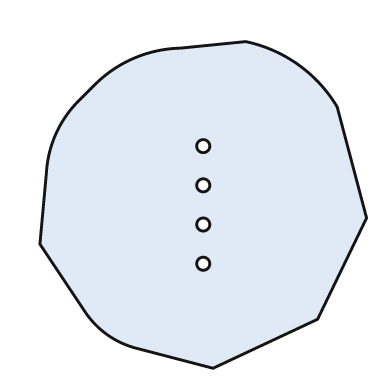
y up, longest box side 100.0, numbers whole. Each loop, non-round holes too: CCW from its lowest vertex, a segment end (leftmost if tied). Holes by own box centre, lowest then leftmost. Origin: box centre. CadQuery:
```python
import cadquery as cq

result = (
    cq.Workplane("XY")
    .moveTo(3.0, -50.0)
    .lineTo(35.0, -35.0)
    .lineTo(50.0, -4.0)
    .lineTo(41.0, 30.0)
    .threePointArc((29.0, 43.0), (13.0, 50.0))
    .lineTo(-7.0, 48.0)
    .threePointArc((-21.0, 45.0), (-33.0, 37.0))
    .lineTo(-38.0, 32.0)
    .threePointArc((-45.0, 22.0), (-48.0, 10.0))
    .lineTo(-50.0, -12.0)
    .lineTo(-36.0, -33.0)
    .threePointArc((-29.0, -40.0), (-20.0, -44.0))
    .close()
    .moveTo(0.0, -18.0)
    .circle(2.0)
    .moveTo(0.0, -6.0)
    .circle(2.0)
    .moveTo(0.0, 6.0)
    .circle(2.0)
    .moveTo(0.0, 18.0)
    .circle(2.0)
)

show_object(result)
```